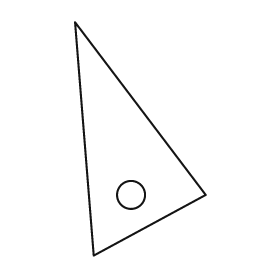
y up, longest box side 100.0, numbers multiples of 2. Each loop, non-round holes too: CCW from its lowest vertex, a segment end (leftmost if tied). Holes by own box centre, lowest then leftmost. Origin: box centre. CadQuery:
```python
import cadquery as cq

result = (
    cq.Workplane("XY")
    .moveTo(-20.0, -50.0)
    .lineTo(28.0, -24.0)
    .lineTo(-28.0, 50.0)
    .close()
    .moveTo(-4.0, -24.0)
    .circle(6.0)
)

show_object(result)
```